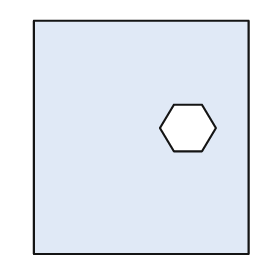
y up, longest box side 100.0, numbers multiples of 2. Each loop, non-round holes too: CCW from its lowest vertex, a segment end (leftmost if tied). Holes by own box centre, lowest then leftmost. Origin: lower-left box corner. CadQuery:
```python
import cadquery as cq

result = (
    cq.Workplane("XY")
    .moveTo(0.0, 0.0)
    .lineTo(92.0, 0.0)
    .lineTo(92.0, 100.0)
    .lineTo(0.0, 100.0)
    .close()
    .moveTo(60.0, 44.0)
    .lineTo(72.0, 44.0)
    .lineTo(78.0, 54.0)
    .lineTo(72.0, 64.0)
    .lineTo(60.0, 64.0)
    .lineTo(54.0, 54.0)
    .close()
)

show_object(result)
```